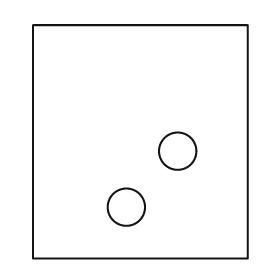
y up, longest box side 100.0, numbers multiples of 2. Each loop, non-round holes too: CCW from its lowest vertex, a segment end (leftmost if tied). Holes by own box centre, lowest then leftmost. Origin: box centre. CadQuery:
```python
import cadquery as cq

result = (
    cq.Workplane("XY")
    .moveTo(-46.0, -50.0)
    .lineTo(46.0, -50.0)
    .lineTo(46.0, 50.0)
    .lineTo(-46.0, 50.0)
    .close()
    .moveTo(-6.0, -28.0)
    .circle(8.0)
    .moveTo(16.0, -4.0)
    .circle(8.0)
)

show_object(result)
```